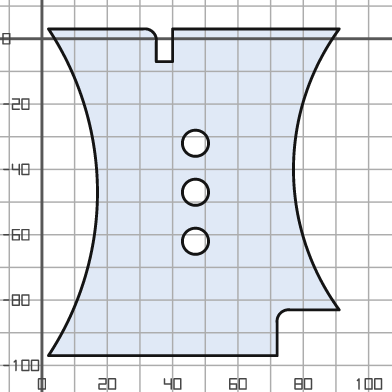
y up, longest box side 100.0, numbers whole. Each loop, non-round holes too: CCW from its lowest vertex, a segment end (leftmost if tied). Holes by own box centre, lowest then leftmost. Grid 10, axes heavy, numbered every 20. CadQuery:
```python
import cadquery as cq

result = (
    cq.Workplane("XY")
    .moveTo(2.0, -97.0)
    .lineTo(72.0, -97.0)
    .lineTo(72.0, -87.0)
    .threePointArc((73.0, -84.0), (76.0, -83.0))
    .lineTo(91.0, -83.0)
    .threePointArc((77.0, -40.0), (91.0, 3.0))
    .lineTo(40.0, 3.0)
    .lineTo(40.0, -7.0)
    .lineTo(35.0, -7.0)
    .lineTo(35.0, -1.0)
    .threePointArc((34.0, 2.0), (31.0, 3.0))
    .lineTo(2.0, 3.0)
    .threePointArc((17.0, -47.0), (2.0, -97.0))
    .close()
    .moveTo(47.0, -62.0)
    .circle(4.0)
    .moveTo(47.0, -47.0)
    .circle(4.0)
    .moveTo(47.0, -32.0)
    .circle(4.0)
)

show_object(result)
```